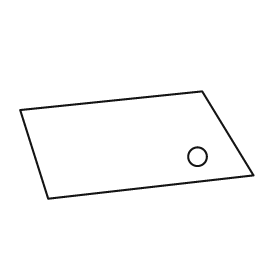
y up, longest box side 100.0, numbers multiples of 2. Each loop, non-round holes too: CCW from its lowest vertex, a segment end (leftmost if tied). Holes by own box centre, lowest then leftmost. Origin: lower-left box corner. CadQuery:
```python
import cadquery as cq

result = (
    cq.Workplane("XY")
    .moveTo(12.0, 0.0)
    .lineTo(100.0, 10.0)
    .lineTo(78.0, 46.0)
    .lineTo(0.0, 38.0)
    .close()
    .moveTo(76.0, 18.0)
    .circle(4.0)
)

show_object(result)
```